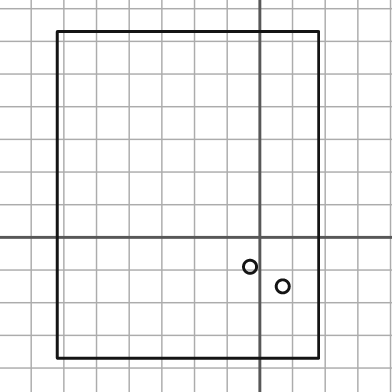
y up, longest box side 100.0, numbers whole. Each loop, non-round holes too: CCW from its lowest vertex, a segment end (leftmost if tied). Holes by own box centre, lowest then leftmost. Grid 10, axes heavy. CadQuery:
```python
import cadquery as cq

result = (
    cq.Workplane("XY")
    .moveTo(-62.0, -37.0)
    .lineTo(18.0, -37.0)
    .lineTo(18.0, 63.0)
    .lineTo(-62.0, 63.0)
    .close()
    .moveTo(7.0, -15.0)
    .circle(2.0)
    .moveTo(-3.0, -9.0)
    .circle(2.0)
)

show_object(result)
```